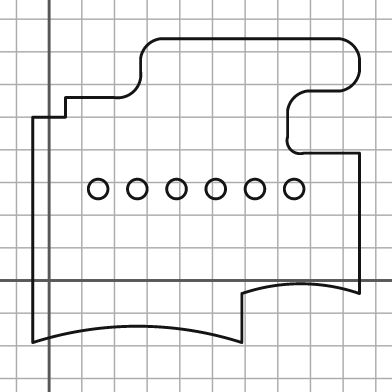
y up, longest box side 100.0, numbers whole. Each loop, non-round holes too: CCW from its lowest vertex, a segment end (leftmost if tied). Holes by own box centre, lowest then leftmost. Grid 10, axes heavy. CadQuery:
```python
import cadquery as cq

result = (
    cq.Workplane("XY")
    .moveTo(-5.0, -19.0)
    .threePointArc((27.0, -14.0), (59.0, -19.0))
    .lineTo(59.0, -4.0)
    .threePointArc((77.0, -1.0), (95.0, -4.0))
    .lineTo(95.0, 39.0)
    .lineTo(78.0, 39.0)
    .threePointArc((74.0, 40.0), (73.0, 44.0))
    .lineTo(73.0, 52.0)
    .threePointArc((75.0, 56.0), (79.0, 58.0))
    .lineTo(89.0, 58.0)
    .threePointArc((93.0, 60.0), (95.0, 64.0))
    .lineTo(95.0, 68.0)
    .threePointArc((93.0, 72.0), (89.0, 74.0))
    .lineTo(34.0, 74.0)
    .threePointArc((30.0, 72.0), (28.0, 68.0))
    .lineTo(28.0, 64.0)
    .threePointArc((26.0, 58.0), (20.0, 56.0))
    .lineTo(5.0, 56.0)
    .lineTo(5.0, 50.0)
    .lineTo(-5.0, 50.0)
    .close()
    .moveTo(15.0, 28.0)
    .circle(3.0)
    .moveTo(27.0, 28.0)
    .circle(3.0)
    .moveTo(39.0, 28.0)
    .circle(3.0)
    .moveTo(51.0, 28.0)
    .circle(3.0)
    .moveTo(63.0, 28.0)
    .circle(3.0)
    .moveTo(75.0, 28.0)
    .circle(3.0)
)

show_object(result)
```